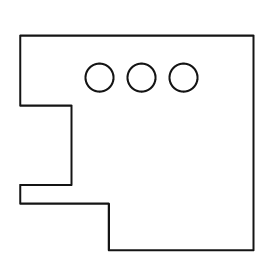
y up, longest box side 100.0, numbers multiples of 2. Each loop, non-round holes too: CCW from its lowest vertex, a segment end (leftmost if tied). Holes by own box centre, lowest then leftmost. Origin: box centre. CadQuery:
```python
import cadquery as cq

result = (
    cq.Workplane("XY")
    .moveTo(-12.0, -46.0)
    .lineTo(50.0, -46.0)
    .lineTo(50.0, 46.0)
    .lineTo(-50.0, 46.0)
    .lineTo(-50.0, 16.0)
    .lineTo(-28.0, 16.0)
    .lineTo(-28.0, -18.0)
    .lineTo(-50.0, -18.0)
    .lineTo(-50.0, -26.0)
    .lineTo(-12.0, -26.0)
    .close()
    .moveTo(-16.0, 28.0)
    .circle(6.0)
    .moveTo(2.0, 28.0)
    .circle(6.0)
    .moveTo(20.0, 28.0)
    .circle(6.0)
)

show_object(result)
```